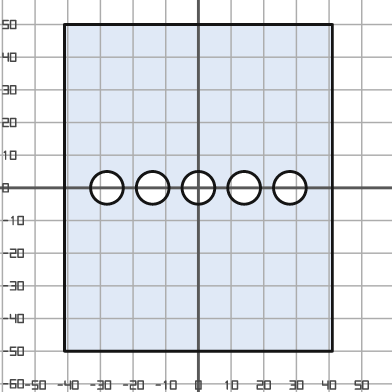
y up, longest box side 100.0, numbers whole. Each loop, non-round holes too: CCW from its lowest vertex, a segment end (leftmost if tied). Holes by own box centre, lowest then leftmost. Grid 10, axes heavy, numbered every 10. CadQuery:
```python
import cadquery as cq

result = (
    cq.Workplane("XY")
    .moveTo(-41.0, -50.0)
    .lineTo(41.0, -50.0)
    .lineTo(41.0, 50.0)
    .lineTo(-41.0, 50.0)
    .close()
    .moveTo(-28.0, 0.0)
    .circle(5.0)
    .moveTo(-14.0, 0.0)
    .circle(5.0)
    .moveTo(0.0, 0.0)
    .circle(5.0)
    .moveTo(14.0, 0.0)
    .circle(5.0)
    .moveTo(28.0, 0.0)
    .circle(5.0)
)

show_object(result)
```